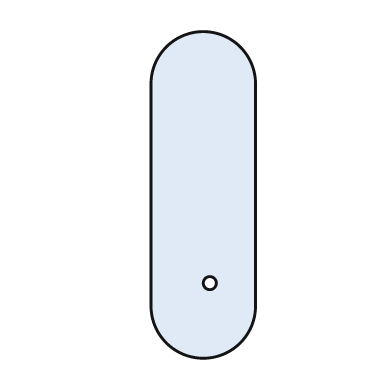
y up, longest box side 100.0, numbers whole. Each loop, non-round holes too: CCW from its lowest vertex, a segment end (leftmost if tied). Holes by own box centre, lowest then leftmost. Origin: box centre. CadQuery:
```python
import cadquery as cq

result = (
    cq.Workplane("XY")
    .moveTo(-16.0, -34.0)
    .threePointArc((0.0, -50.0), (16.0, -34.0))
    .lineTo(16.0, 34.0)
    .threePointArc((0.0, 50.0), (-16.0, 34.0))
    .close()
    .moveTo(2.0, -27.0)
    .circle(2.0)
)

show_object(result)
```